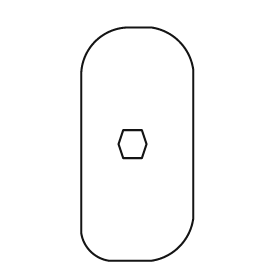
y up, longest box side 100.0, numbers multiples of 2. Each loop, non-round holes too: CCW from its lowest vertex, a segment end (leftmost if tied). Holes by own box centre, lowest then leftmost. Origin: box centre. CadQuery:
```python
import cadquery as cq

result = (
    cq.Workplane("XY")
    .moveTo(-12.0, -50.0)
    .lineTo(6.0, -50.0)
    .threePointArc((18.0, -44.0), (24.0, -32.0))
    .lineTo(24.0, 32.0)
    .threePointArc((18.0, 44.0), (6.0, 50.0))
    .lineTo(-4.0, 50.0)
    .threePointArc((-18.0, 44.0), (-24.0, 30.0))
    .lineTo(-24.0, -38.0)
    .threePointArc((-20.0, -46.0), (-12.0, -50.0))
    .close()
    .moveTo(-6.0, -6.0)
    .lineTo(2.0, -6.0)
    .lineTo(4.0, 0.0)
    .lineTo(2.0, 6.0)
    .lineTo(-6.0, 6.0)
    .lineTo(-8.0, 0.0)
    .close()
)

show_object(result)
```